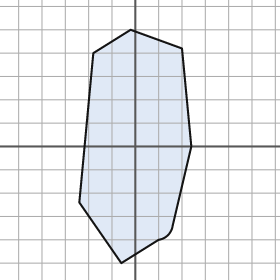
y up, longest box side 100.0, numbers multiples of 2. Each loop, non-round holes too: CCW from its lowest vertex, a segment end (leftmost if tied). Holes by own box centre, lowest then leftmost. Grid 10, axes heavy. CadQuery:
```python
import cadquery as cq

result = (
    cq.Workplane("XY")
    .moveTo(-6.0, -50.0)
    .lineTo(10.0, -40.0)
    .threePointArc((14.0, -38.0), (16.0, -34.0))
    .lineTo(24.0, 0.0)
    .lineTo(20.0, 42.0)
    .lineTo(-2.0, 50.0)
    .lineTo(-18.0, 40.0)
    .lineTo(-24.0, -24.0)
    .close()
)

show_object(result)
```